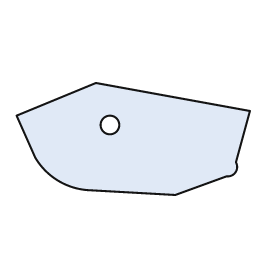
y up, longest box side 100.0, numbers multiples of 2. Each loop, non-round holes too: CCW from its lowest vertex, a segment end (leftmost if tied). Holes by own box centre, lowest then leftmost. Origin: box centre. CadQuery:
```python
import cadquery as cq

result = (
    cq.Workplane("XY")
    .moveTo(18.0, -24.0)
    .lineTo(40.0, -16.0)
    .threePointArc((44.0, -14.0), (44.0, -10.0))
    .lineTo(50.0, 12.0)
    .lineTo(-16.0, 24.0)
    .lineTo(-50.0, 10.0)
    .lineTo(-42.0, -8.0)
    .threePointArc((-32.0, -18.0), (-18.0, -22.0))
    .close()
    .moveTo(-10.0, 6.0)
    .circle(4.0)
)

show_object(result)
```